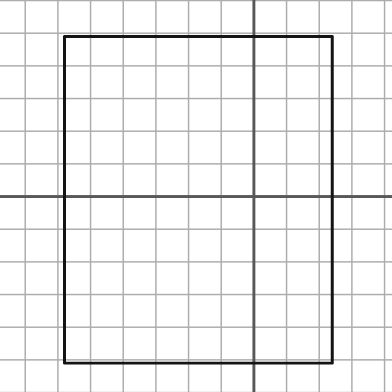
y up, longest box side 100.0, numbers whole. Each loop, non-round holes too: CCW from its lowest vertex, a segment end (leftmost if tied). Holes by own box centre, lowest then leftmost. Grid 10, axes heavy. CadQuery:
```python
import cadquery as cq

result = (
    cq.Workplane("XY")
    .moveTo(-58.0, -51.0)
    .lineTo(24.0, -51.0)
    .lineTo(24.0, 49.0)
    .lineTo(-58.0, 49.0)
    .close()
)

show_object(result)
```